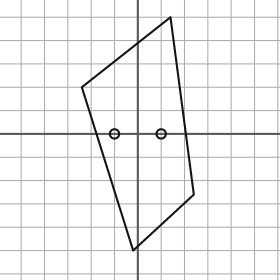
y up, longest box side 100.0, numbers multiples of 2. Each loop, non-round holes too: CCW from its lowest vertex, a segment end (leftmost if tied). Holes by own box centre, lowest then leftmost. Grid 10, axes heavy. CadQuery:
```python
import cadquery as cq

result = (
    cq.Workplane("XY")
    .moveTo(-2.0, -50.0)
    .lineTo(24.0, -26.0)
    .lineTo(14.0, 50.0)
    .lineTo(-24.0, 20.0)
    .close()
    .moveTo(-10.0, 0.0)
    .circle(2.0)
    .moveTo(10.0, 0.0)
    .circle(2.0)
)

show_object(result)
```